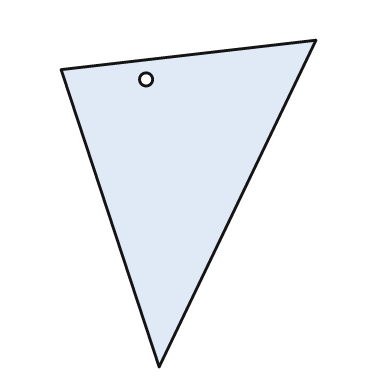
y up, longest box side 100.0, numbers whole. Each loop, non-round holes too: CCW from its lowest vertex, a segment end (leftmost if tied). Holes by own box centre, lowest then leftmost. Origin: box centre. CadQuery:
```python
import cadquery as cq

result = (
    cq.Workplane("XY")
    .moveTo(-9.0, -50.0)
    .lineTo(39.0, 50.0)
    .lineTo(-39.0, 41.0)
    .close()
    .moveTo(-13.0, 38.0)
    .circle(2.0)
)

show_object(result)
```